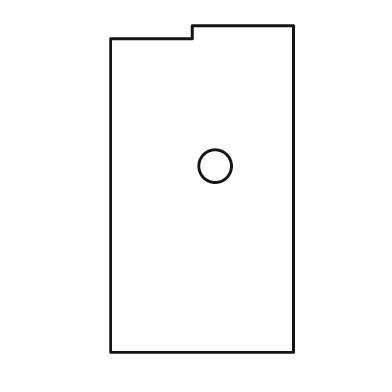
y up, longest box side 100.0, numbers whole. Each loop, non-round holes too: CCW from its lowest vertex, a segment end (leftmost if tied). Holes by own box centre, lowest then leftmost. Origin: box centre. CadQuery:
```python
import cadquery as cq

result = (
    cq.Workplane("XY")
    .moveTo(-28.0, -50.0)
    .lineTo(28.0, -50.0)
    .lineTo(28.0, 50.0)
    .lineTo(-3.0, 50.0)
    .lineTo(-3.0, 46.0)
    .lineTo(-28.0, 46.0)
    .close()
    .moveTo(4.0, 7.0)
    .circle(5.0)
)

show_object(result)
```